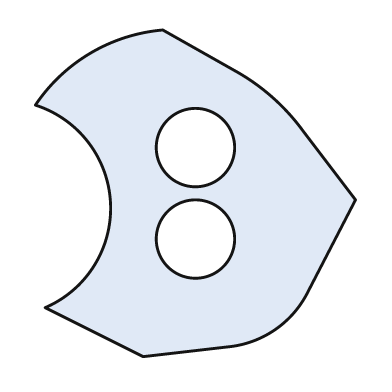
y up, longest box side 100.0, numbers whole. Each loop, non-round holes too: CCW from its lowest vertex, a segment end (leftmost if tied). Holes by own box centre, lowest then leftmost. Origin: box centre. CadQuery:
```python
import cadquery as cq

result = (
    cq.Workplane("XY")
    .moveTo(-16.0, -50.0)
    .lineTo(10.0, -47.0)
    .threePointArc((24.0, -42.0), (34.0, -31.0))
    .lineTo(49.0, -2.0)
    .lineTo(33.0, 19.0)
    .threePointArc((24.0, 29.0), (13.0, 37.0))
    .lineTo(-10.0, 50.0)
    .threePointArc((-32.0, 43.0), (-49.0, 27.0))
    .threePointArc((-26.0, -3.0), (-46.0, -35.0))
    .close()
    .moveTo(0.0, -14.0)
    .circle(12.0)
    .moveTo(0.0, 14.0)
    .circle(12.0)
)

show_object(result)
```